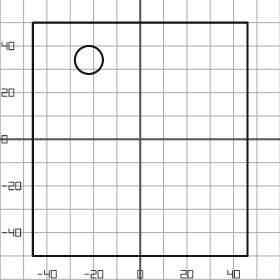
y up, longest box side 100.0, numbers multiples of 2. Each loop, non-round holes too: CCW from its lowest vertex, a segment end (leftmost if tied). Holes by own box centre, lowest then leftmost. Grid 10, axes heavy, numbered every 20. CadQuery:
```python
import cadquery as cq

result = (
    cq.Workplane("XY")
    .moveTo(-46.0, -50.0)
    .lineTo(46.0, -50.0)
    .lineTo(46.0, 50.0)
    .lineTo(-46.0, 50.0)
    .close()
    .moveTo(-22.0, 34.0)
    .circle(6.0)
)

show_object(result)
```